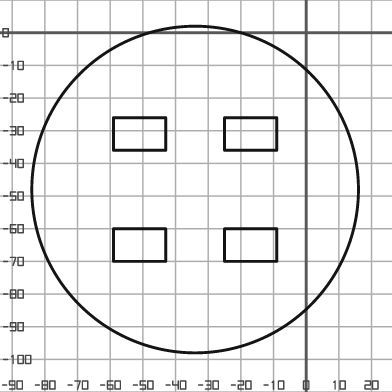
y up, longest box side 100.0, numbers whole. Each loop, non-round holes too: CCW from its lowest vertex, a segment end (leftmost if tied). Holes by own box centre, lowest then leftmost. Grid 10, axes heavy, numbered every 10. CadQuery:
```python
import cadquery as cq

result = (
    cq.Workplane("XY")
    .moveTo(-34.0, -48.0)
    .circle(50.0)
    .moveTo(-59.0, -70.0)
    .lineTo(-43.0, -70.0)
    .lineTo(-43.0, -60.0)
    .lineTo(-59.0, -60.0)
    .close()
    .moveTo(-25.0, -70.0)
    .lineTo(-9.0, -70.0)
    .lineTo(-9.0, -60.0)
    .lineTo(-25.0, -60.0)
    .close()
    .moveTo(-59.0, -36.0)
    .lineTo(-43.0, -36.0)
    .lineTo(-43.0, -26.0)
    .lineTo(-59.0, -26.0)
    .close()
    .moveTo(-25.0, -36.0)
    .lineTo(-9.0, -36.0)
    .lineTo(-9.0, -26.0)
    .lineTo(-25.0, -26.0)
    .close()
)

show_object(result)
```